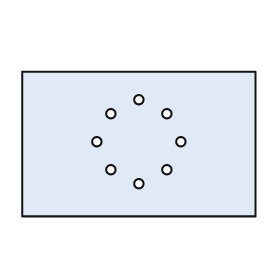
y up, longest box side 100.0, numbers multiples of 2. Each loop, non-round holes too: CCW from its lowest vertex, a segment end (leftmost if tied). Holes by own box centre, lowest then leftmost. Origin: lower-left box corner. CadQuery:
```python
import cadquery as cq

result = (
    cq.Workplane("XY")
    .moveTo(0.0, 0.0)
    .lineTo(100.0, 0.0)
    .lineTo(100.0, 62.0)
    .lineTo(0.0, 62.0)
    .close()
    .moveTo(50.0, 14.0)
    .circle(2.0)
    .moveTo(38.0, 20.0)
    .circle(2.0)
    .moveTo(62.0, 20.0)
    .circle(2.0)
    .moveTo(32.0, 32.0)
    .circle(2.0)
    .moveTo(68.0, 32.0)
    .circle(2.0)
    .moveTo(38.0, 44.0)
    .circle(2.0)
    .moveTo(62.0, 44.0)
    .circle(2.0)
    .moveTo(50.0, 50.0)
    .circle(2.0)
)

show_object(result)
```